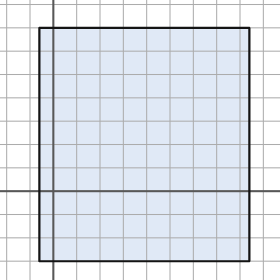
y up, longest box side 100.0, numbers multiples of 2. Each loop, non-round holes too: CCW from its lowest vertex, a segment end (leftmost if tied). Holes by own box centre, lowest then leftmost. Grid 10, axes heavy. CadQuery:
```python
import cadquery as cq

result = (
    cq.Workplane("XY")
    .moveTo(-6.0, -30.0)
    .lineTo(84.0, -30.0)
    .lineTo(84.0, 70.0)
    .lineTo(-6.0, 70.0)
    .close()
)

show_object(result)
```